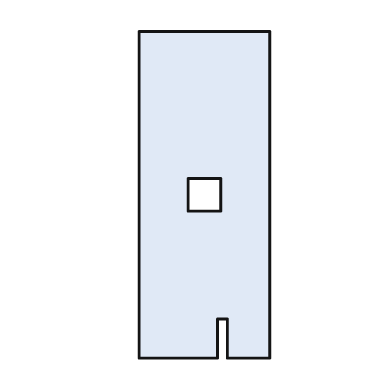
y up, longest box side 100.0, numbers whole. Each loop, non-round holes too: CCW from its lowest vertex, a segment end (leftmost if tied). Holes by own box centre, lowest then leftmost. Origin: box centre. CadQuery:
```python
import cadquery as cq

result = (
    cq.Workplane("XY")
    .moveTo(-20.0, -50.0)
    .lineTo(4.0, -50.0)
    .lineTo(4.0, -38.0)
    .lineTo(7.0, -38.0)
    .lineTo(7.0, -50.0)
    .lineTo(20.0, -50.0)
    .lineTo(20.0, 50.0)
    .lineTo(-20.0, 50.0)
    .close()
    .moveTo(-5.0, -5.0)
    .lineTo(5.0, -5.0)
    .lineTo(5.0, 5.0)
    .lineTo(-5.0, 5.0)
    .close()
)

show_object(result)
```